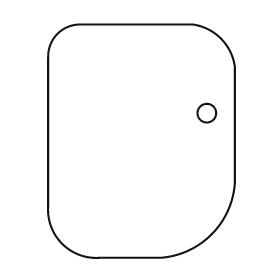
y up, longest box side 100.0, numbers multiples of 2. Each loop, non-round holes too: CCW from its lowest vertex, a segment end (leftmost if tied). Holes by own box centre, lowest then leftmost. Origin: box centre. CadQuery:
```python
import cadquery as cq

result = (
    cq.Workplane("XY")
    .moveTo(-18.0, -50.0)
    .lineTo(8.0, -50.0)
    .threePointArc((30.0, -40.0), (40.0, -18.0))
    .lineTo(40.0, 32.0)
    .threePointArc((34.0, 44.0), (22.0, 50.0))
    .lineTo(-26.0, 50.0)
    .threePointArc((-36.0, 46.0), (-40.0, 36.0))
    .lineTo(-40.0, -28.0)
    .threePointArc((-34.0, -44.0), (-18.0, -50.0))
    .close()
    .moveTo(28.0, 12.0)
    .circle(4.0)
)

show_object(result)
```